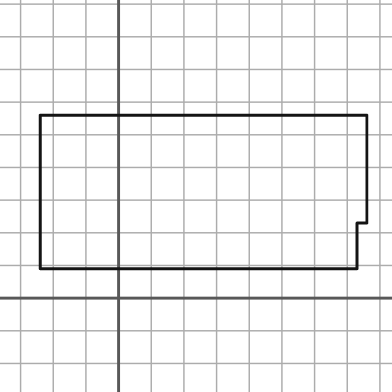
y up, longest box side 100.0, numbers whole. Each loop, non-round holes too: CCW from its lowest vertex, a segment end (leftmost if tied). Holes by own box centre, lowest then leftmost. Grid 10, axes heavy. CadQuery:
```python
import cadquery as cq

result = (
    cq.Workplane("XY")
    .moveTo(-24.0, 9.0)
    .lineTo(73.0, 9.0)
    .lineTo(73.0, 23.0)
    .lineTo(76.0, 23.0)
    .lineTo(76.0, 56.0)
    .lineTo(-24.0, 56.0)
    .close()
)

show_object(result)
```